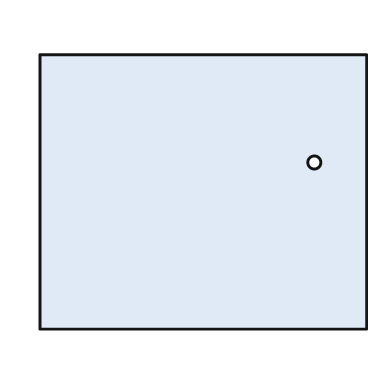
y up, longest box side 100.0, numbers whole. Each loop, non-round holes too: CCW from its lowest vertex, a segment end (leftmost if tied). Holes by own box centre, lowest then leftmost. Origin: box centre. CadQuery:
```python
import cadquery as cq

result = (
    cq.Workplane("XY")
    .moveTo(-50.0, -42.0)
    .lineTo(50.0, -42.0)
    .lineTo(50.0, 42.0)
    .lineTo(-50.0, 42.0)
    .close()
    .moveTo(34.0, 9.0)
    .circle(2.0)
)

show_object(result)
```